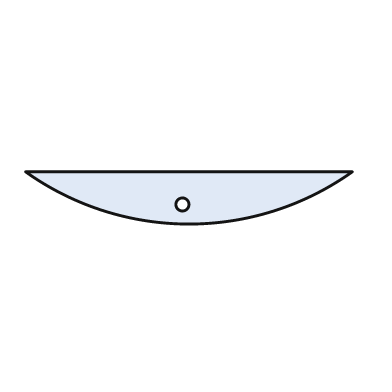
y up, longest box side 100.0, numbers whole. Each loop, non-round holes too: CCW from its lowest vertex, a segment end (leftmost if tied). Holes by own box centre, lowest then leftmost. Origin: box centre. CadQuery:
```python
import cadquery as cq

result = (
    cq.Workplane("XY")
    .moveTo(-50.0, 8.0)
    .threePointArc((0.0, -8.0), (50.0, 8.0))
    .close()
    .moveTo(-2.0, -2.0)
    .circle(2.0)
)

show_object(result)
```